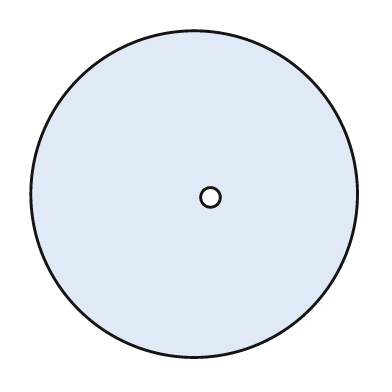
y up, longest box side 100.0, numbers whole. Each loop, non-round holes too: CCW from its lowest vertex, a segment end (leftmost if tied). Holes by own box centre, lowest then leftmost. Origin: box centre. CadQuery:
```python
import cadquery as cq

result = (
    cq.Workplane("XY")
    .moveTo(0.0, 0.0)
    .circle(50.0)
    .moveTo(5.0, -1.0)
    .circle(3.0)
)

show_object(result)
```